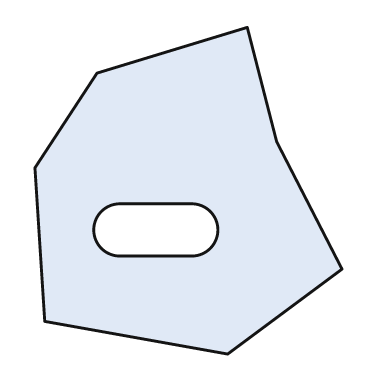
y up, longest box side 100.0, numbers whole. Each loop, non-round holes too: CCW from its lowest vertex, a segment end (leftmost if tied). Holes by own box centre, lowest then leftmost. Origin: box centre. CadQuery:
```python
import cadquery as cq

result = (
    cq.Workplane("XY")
    .moveTo(12.0, -50.0)
    .lineTo(47.0, -24.0)
    .lineTo(27.0, 15.0)
    .lineTo(18.0, 50.0)
    .lineTo(-28.0, 36.0)
    .lineTo(-47.0, 7.0)
    .lineTo(-44.0, -40.0)
    .close()
    .moveTo(-21.0, -20.0)
    .lineTo(1.0, -20.0)
    .threePointArc((9.0, -12.0), (1.0, -4.0))
    .lineTo(-21.0, -4.0)
    .threePointArc((-29.0, -12.0), (-21.0, -20.0))
    .close()
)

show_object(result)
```